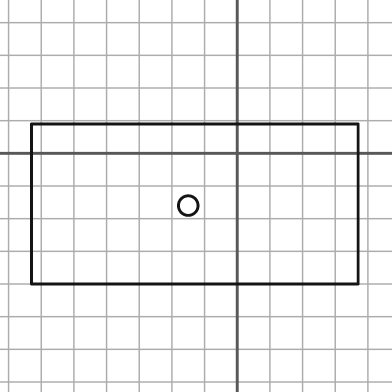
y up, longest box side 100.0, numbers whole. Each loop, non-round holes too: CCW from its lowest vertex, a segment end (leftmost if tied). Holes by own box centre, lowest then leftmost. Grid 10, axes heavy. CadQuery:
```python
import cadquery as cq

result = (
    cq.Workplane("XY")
    .moveTo(-63.0, -40.0)
    .lineTo(37.0, -40.0)
    .lineTo(37.0, 9.0)
    .lineTo(-63.0, 9.0)
    .close()
    .moveTo(-15.0, -16.0)
    .circle(3.0)
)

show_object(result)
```